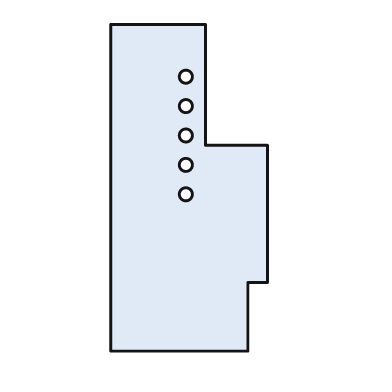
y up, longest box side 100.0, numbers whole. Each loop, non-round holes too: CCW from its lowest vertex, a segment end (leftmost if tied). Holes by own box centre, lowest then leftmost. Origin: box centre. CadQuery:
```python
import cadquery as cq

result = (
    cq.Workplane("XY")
    .moveTo(-24.0, -50.0)
    .lineTo(18.0, -50.0)
    .lineTo(18.0, -29.0)
    .lineTo(24.0, -29.0)
    .lineTo(24.0, 13.0)
    .lineTo(5.0, 13.0)
    .lineTo(5.0, 50.0)
    .lineTo(-24.0, 50.0)
    .close()
    .moveTo(-1.0, -2.0)
    .circle(2.0)
    .moveTo(-1.0, 7.0)
    .circle(2.0)
    .moveTo(-1.0, 16.0)
    .circle(2.0)
    .moveTo(-1.0, 25.0)
    .circle(2.0)
    .moveTo(-1.0, 34.0)
    .circle(2.0)
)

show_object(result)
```